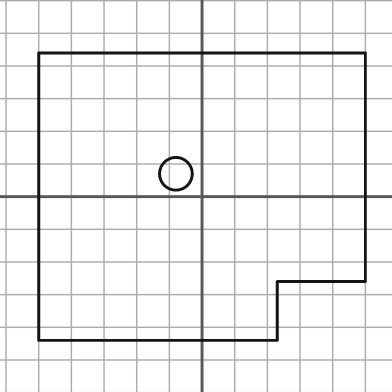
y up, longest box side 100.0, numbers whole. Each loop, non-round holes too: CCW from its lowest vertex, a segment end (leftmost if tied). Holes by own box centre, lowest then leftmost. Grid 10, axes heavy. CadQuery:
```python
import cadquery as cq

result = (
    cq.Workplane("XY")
    .moveTo(-50.0, -44.0)
    .lineTo(23.0, -44.0)
    .lineTo(23.0, -26.0)
    .lineTo(50.0, -26.0)
    .lineTo(50.0, 44.0)
    .lineTo(-50.0, 44.0)
    .close()
    .moveTo(-8.0, 7.0)
    .circle(5.0)
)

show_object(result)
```